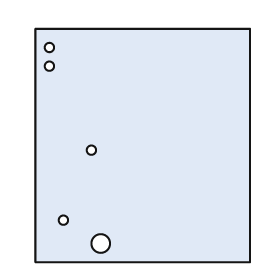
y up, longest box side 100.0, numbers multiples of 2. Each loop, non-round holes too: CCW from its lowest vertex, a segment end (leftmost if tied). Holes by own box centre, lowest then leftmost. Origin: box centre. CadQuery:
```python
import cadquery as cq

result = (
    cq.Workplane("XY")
    .moveTo(-46.0, -50.0)
    .lineTo(46.0, -50.0)
    .lineTo(46.0, 50.0)
    .lineTo(-46.0, 50.0)
    .close()
    .moveTo(-18.0, -42.0)
    .circle(4.0)
    .moveTo(-34.0, -32.0)
    .circle(2.0)
    .moveTo(-22.0, -2.0)
    .circle(2.0)
    .moveTo(-40.0, 34.0)
    .circle(2.0)
    .moveTo(-40.0, 42.0)
    .circle(2.0)
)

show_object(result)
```